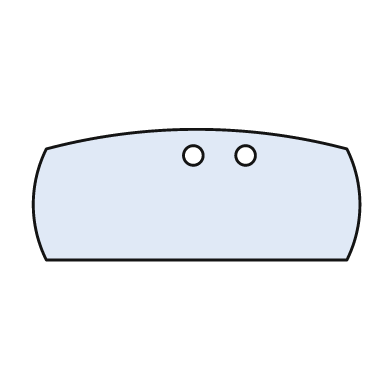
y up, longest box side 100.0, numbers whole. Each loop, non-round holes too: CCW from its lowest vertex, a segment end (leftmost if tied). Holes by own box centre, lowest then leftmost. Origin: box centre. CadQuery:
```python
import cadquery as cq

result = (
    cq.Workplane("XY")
    .moveTo(-46.0, -20.0)
    .lineTo(46.0, -20.0)
    .threePointArc((50.0, -3.0), (46.0, 14.0))
    .threePointArc((0.0, 20.0), (-46.0, 14.0))
    .threePointArc((-50.0, -3.0), (-46.0, -20.0))
    .close()
    .moveTo(-1.0, 12.0)
    .circle(3.0)
    .moveTo(15.0, 12.0)
    .circle(3.0)
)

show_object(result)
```